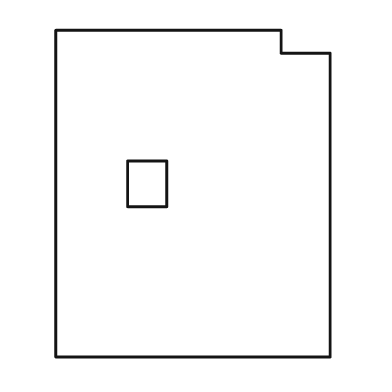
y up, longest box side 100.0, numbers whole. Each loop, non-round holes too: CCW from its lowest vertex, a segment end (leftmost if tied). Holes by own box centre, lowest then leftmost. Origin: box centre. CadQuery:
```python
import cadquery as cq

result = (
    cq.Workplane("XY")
    .moveTo(-42.0, -50.0)
    .lineTo(42.0, -50.0)
    .lineTo(42.0, 43.0)
    .lineTo(27.0, 43.0)
    .lineTo(27.0, 50.0)
    .lineTo(-42.0, 50.0)
    .close()
    .moveTo(-20.0, -4.0)
    .lineTo(-8.0, -4.0)
    .lineTo(-8.0, 10.0)
    .lineTo(-20.0, 10.0)
    .close()
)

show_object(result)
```